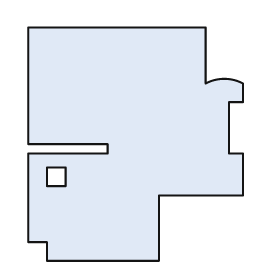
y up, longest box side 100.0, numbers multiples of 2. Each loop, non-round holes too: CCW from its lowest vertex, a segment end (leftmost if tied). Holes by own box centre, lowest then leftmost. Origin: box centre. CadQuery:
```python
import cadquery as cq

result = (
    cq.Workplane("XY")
    .moveTo(-38.0, -50.0)
    .lineTo(10.0, -50.0)
    .lineTo(10.0, -22.0)
    .lineTo(46.0, -22.0)
    .lineTo(46.0, -4.0)
    .lineTo(40.0, -4.0)
    .lineTo(40.0, 18.0)
    .lineTo(46.0, 18.0)
    .lineTo(46.0, 26.0)
    .threePointArc((38.0, 28.0), (30.0, 26.0))
    .lineTo(30.0, 50.0)
    .lineTo(-46.0, 50.0)
    .lineTo(-46.0, 0.0)
    .lineTo(-12.0, 0.0)
    .lineTo(-12.0, -4.0)
    .lineTo(-46.0, -4.0)
    .lineTo(-46.0, -42.0)
    .lineTo(-38.0, -42.0)
    .close()
    .moveTo(-38.0, -18.0)
    .lineTo(-30.0, -18.0)
    .lineTo(-30.0, -10.0)
    .lineTo(-38.0, -10.0)
    .close()
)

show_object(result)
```